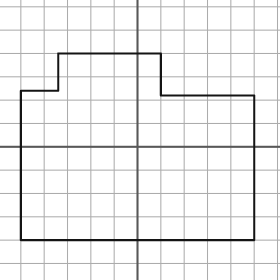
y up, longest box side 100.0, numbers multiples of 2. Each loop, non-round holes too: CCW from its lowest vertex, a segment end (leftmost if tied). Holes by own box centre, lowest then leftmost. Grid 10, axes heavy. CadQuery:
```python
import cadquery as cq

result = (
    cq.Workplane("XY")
    .moveTo(-50.0, -40.0)
    .lineTo(50.0, -40.0)
    .lineTo(50.0, 22.0)
    .lineTo(10.0, 22.0)
    .lineTo(10.0, 40.0)
    .lineTo(-34.0, 40.0)
    .lineTo(-34.0, 24.0)
    .lineTo(-50.0, 24.0)
    .close()
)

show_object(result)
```